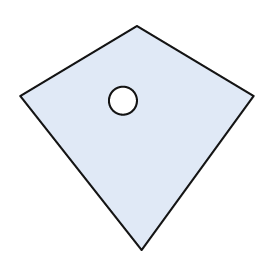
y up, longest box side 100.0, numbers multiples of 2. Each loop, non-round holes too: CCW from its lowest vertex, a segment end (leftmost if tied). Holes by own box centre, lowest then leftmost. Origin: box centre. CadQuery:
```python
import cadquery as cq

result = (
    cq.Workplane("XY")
    .moveTo(2.0, -48.0)
    .lineTo(50.0, 18.0)
    .lineTo(0.0, 48.0)
    .lineTo(-50.0, 18.0)
    .close()
    .moveTo(-6.0, 16.0)
    .circle(6.0)
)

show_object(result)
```